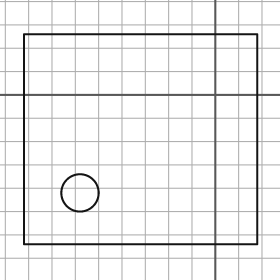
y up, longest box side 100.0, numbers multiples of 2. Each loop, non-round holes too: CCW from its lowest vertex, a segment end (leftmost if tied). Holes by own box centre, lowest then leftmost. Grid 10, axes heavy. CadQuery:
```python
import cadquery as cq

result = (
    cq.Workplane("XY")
    .moveTo(-82.0, -64.0)
    .lineTo(18.0, -64.0)
    .lineTo(18.0, 26.0)
    .lineTo(-82.0, 26.0)
    .close()
    .moveTo(-58.0, -42.0)
    .circle(8.0)
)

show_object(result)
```